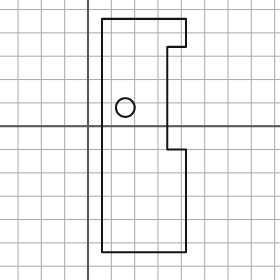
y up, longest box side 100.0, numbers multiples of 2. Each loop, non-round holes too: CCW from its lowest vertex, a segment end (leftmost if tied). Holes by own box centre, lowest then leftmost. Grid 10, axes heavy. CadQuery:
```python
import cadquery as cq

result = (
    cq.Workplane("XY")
    .moveTo(6.0, -54.0)
    .lineTo(42.0, -54.0)
    .lineTo(42.0, -10.0)
    .lineTo(34.0, -10.0)
    .lineTo(34.0, 34.0)
    .lineTo(42.0, 34.0)
    .lineTo(42.0, 46.0)
    .lineTo(6.0, 46.0)
    .close()
    .moveTo(16.0, 8.0)
    .circle(4.0)
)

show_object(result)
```